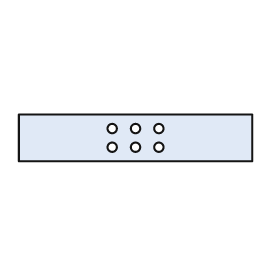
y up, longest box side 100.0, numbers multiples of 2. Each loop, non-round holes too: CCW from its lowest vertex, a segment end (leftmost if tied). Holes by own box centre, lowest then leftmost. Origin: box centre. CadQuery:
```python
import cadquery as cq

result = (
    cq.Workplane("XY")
    .moveTo(-50.0, -10.0)
    .lineTo(50.0, -10.0)
    .lineTo(50.0, 10.0)
    .lineTo(-50.0, 10.0)
    .close()
    .moveTo(-10.0, -4.0)
    .circle(2.0)
    .moveTo(0.0, -4.0)
    .circle(2.0)
    .moveTo(10.0, -4.0)
    .circle(2.0)
    .moveTo(-10.0, 4.0)
    .circle(2.0)
    .moveTo(0.0, 4.0)
    .circle(2.0)
    .moveTo(10.0, 4.0)
    .circle(2.0)
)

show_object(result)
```